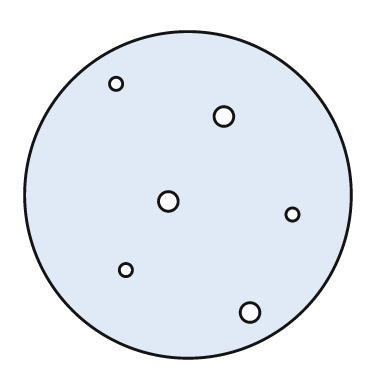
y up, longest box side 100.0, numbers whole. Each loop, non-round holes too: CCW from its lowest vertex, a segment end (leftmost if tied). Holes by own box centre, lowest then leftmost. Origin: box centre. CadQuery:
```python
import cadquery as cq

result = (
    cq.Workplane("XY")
    .moveTo(0.0, 0.0)
    .circle(50.0)
    .moveTo(19.0, -36.0)
    .circle(3.0)
    .moveTo(-19.0, -23.0)
    .circle(2.0)
    .moveTo(32.0, -6.0)
    .circle(2.0)
    .moveTo(-6.0, -2.0)
    .circle(3.0)
    .moveTo(11.0, 24.0)
    .circle(3.0)
    .moveTo(-22.0, 34.0)
    .circle(2.0)
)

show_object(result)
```